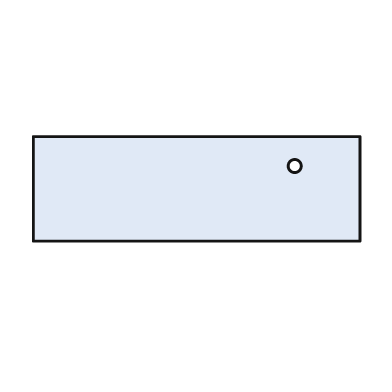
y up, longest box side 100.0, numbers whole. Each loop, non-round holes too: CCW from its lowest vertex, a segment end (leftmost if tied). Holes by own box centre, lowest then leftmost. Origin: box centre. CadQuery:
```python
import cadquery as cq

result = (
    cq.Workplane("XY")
    .moveTo(-50.0, -16.0)
    .lineTo(50.0, -16.0)
    .lineTo(50.0, 16.0)
    .lineTo(-50.0, 16.0)
    .close()
    .moveTo(30.0, 7.0)
    .circle(2.0)
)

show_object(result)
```